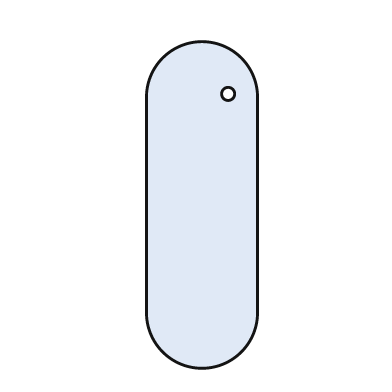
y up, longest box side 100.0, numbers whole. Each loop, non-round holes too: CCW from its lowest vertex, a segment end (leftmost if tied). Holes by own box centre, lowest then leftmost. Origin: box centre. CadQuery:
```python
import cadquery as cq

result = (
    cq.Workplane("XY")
    .moveTo(-17.0, -33.0)
    .threePointArc((0.0, -50.0), (17.0, -33.0))
    .lineTo(17.0, 33.0)
    .threePointArc((0.0, 50.0), (-17.0, 33.0))
    .close()
    .moveTo(8.0, 34.0)
    .circle(2.0)
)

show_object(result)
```